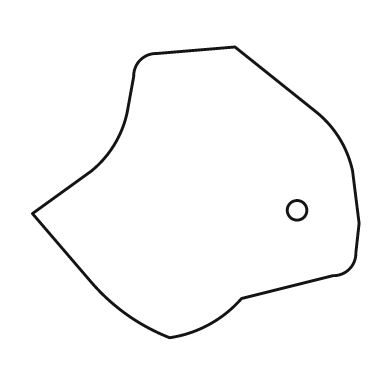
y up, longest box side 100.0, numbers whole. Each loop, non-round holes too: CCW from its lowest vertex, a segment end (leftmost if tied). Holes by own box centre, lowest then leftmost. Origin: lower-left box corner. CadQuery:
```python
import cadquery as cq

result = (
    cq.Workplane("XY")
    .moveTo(42.0, 0.0)
    .threePointArc((54.0, 4.0), (64.0, 12.0))
    .lineTo(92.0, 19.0)
    .threePointArc((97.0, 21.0), (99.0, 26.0))
    .lineTo(100.0, 35.0)
    .lineTo(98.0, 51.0)
    .threePointArc((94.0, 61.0), (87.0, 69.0))
    .lineTo(62.0, 89.0)
    .lineTo(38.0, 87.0)
    .threePointArc((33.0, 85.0), (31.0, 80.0))
    .lineTo(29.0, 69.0)
    .threePointArc((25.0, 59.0), (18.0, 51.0))
    .lineTo(0.0, 38.0)
    .lineTo(18.0, 17.0)
    .threePointArc((29.0, 7.0), (42.0, 0.0))
    .close()
    .moveTo(81.0, 39.0)
    .circle(3.0)
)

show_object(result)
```